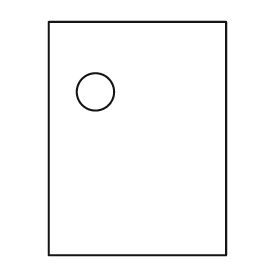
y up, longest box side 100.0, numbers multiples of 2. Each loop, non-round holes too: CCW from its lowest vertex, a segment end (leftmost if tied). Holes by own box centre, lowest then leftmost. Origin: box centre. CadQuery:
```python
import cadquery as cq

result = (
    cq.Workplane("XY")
    .moveTo(-38.0, -50.0)
    .lineTo(38.0, -50.0)
    .lineTo(38.0, 50.0)
    .lineTo(-38.0, 50.0)
    .close()
    .moveTo(-18.0, 20.0)
    .circle(8.0)
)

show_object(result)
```